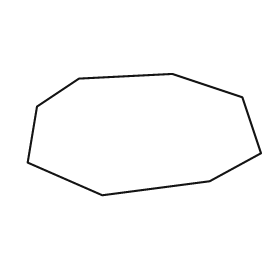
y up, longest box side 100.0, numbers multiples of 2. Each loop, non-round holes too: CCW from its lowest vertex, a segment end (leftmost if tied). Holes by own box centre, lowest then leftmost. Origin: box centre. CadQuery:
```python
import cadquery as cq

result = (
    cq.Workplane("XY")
    .moveTo(-18.0, -26.0)
    .lineTo(28.0, -20.0)
    .lineTo(50.0, -8.0)
    .lineTo(42.0, 16.0)
    .lineTo(12.0, 26.0)
    .lineTo(-28.0, 24.0)
    .lineTo(-46.0, 12.0)
    .lineTo(-50.0, -12.0)
    .close()
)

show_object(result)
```